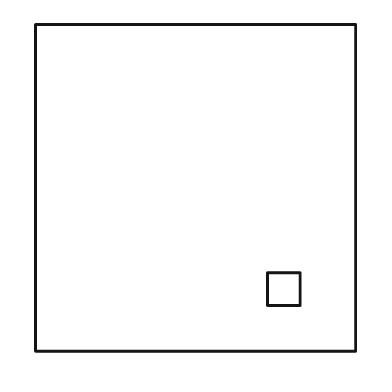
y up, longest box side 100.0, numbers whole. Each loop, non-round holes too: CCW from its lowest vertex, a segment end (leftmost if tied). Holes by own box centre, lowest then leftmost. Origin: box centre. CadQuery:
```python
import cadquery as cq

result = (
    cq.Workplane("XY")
    .moveTo(-49.0, -50.0)
    .lineTo(49.0, -50.0)
    .lineTo(49.0, 50.0)
    .lineTo(-49.0, 50.0)
    .close()
    .moveTo(22.0, -36.0)
    .lineTo(32.0, -36.0)
    .lineTo(32.0, -26.0)
    .lineTo(22.0, -26.0)
    .close()
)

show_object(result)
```